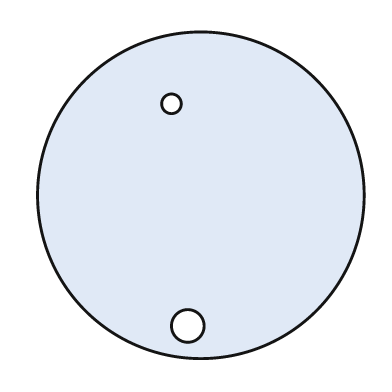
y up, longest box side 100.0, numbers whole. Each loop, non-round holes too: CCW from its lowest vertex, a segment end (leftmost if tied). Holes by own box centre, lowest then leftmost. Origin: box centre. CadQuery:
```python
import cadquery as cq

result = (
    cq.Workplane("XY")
    .moveTo(0.0, 0.0)
    .circle(50.0)
    .moveTo(-4.0, -40.0)
    .circle(5.0)
    .moveTo(-9.0, 28.0)
    .circle(3.0)
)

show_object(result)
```